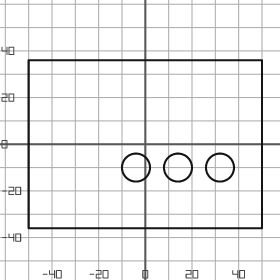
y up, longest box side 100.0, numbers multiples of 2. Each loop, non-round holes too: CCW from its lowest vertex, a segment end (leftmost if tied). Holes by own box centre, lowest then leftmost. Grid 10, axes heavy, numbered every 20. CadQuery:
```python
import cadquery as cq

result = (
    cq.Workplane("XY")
    .moveTo(-50.0, -36.0)
    .lineTo(50.0, -36.0)
    .lineTo(50.0, 36.0)
    .lineTo(-50.0, 36.0)
    .close()
    .moveTo(-4.0, -10.0)
    .circle(6.0)
    .moveTo(14.0, -10.0)
    .circle(6.0)
    .moveTo(32.0, -10.0)
    .circle(6.0)
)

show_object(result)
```